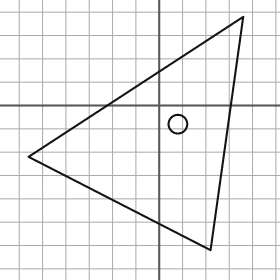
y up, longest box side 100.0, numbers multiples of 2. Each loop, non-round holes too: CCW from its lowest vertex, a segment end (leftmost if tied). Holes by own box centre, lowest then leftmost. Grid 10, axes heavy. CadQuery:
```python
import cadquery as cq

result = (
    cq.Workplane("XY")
    .moveTo(22.0, -62.0)
    .lineTo(36.0, 38.0)
    .lineTo(-56.0, -22.0)
    .close()
    .moveTo(8.0, -8.0)
    .circle(4.0)
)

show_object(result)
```